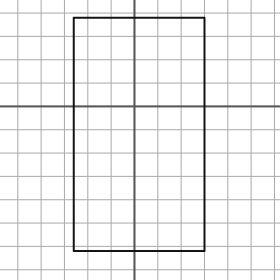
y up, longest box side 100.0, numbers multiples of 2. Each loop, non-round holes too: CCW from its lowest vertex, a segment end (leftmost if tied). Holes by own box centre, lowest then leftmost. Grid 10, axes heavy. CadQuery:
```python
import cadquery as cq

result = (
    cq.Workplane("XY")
    .moveTo(-26.0, -62.0)
    .lineTo(30.0, -62.0)
    .lineTo(30.0, 38.0)
    .lineTo(-26.0, 38.0)
    .close()
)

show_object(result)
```